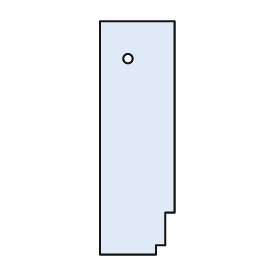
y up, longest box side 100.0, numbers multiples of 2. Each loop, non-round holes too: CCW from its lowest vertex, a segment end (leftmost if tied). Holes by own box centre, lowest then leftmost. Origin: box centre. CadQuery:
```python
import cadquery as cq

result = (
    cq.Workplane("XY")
    .moveTo(-16.0, -50.0)
    .lineTo(8.0, -50.0)
    .lineTo(8.0, -46.0)
    .lineTo(12.0, -46.0)
    .lineTo(12.0, -32.0)
    .lineTo(16.0, -32.0)
    .lineTo(16.0, 50.0)
    .lineTo(-16.0, 50.0)
    .close()
    .moveTo(-4.0, 34.0)
    .circle(2.0)
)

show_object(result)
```